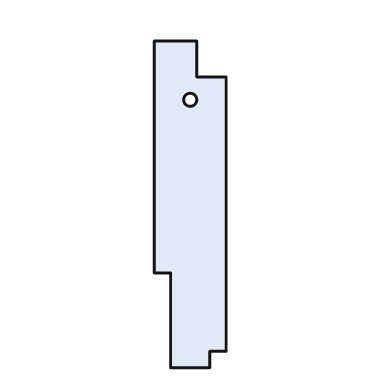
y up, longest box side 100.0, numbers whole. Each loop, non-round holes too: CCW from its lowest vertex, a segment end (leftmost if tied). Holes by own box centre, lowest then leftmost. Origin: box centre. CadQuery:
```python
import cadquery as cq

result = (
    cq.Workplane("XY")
    .moveTo(-6.0, -50.0)
    .lineTo(6.0, -50.0)
    .lineTo(6.0, -45.0)
    .lineTo(11.0, -45.0)
    .lineTo(11.0, 39.0)
    .lineTo(2.0, 39.0)
    .lineTo(2.0, 50.0)
    .lineTo(-11.0, 50.0)
    .lineTo(-11.0, -21.0)
    .lineTo(-6.0, -21.0)
    .close()
    .moveTo(0.0, 32.0)
    .circle(2.0)
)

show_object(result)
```